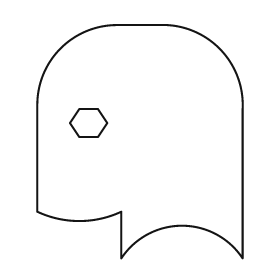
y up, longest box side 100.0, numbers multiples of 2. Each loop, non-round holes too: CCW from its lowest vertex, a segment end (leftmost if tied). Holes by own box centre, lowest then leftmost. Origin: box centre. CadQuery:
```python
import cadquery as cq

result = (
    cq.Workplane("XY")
    .moveTo(-8.0, -50.0)
    .threePointArc((18.0, -36.0), (44.0, -50.0))
    .lineTo(44.0, 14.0)
    .threePointArc((34.0, 40.0), (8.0, 50.0))
    .lineTo(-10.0, 50.0)
    .threePointArc((-34.0, 40.0), (-44.0, 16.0))
    .lineTo(-44.0, -30.0)
    .threePointArc((-26.0, -34.0), (-8.0, -30.0))
    .close()
    .moveTo(-26.0, 2.0)
    .lineTo(-18.0, 2.0)
    .lineTo(-14.0, 8.0)
    .lineTo(-18.0, 14.0)
    .lineTo(-26.0, 14.0)
    .lineTo(-30.0, 8.0)
    .close()
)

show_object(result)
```